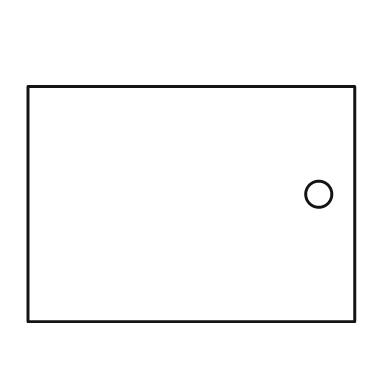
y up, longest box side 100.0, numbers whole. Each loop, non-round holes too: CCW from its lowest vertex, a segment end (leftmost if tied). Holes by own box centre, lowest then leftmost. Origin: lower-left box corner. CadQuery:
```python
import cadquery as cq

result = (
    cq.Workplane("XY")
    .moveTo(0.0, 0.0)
    .lineTo(100.0, 0.0)
    .lineTo(100.0, 72.0)
    .lineTo(0.0, 72.0)
    .close()
    .moveTo(89.0, 39.0)
    .circle(4.0)
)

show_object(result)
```